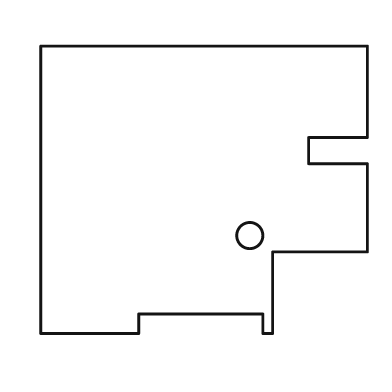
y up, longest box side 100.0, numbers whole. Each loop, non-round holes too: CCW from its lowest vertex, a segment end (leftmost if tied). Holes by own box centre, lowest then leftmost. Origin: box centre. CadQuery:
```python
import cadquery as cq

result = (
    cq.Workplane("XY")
    .moveTo(-50.0, -44.0)
    .lineTo(-20.0, -44.0)
    .lineTo(-20.0, -38.0)
    .lineTo(18.0, -38.0)
    .lineTo(18.0, -44.0)
    .lineTo(21.0, -44.0)
    .lineTo(21.0, -19.0)
    .lineTo(50.0, -19.0)
    .lineTo(50.0, 8.0)
    .lineTo(32.0, 8.0)
    .lineTo(32.0, 16.0)
    .lineTo(50.0, 16.0)
    .lineTo(50.0, 44.0)
    .lineTo(-50.0, 44.0)
    .close()
    .moveTo(14.0, -14.0)
    .circle(4.0)
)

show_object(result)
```